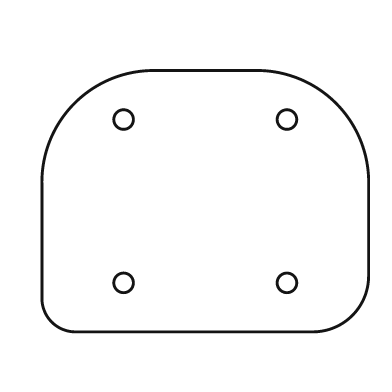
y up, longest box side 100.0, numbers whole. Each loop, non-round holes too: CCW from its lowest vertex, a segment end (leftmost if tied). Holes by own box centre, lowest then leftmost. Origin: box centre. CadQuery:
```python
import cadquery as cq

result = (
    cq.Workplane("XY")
    .moveTo(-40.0, -40.0)
    .lineTo(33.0, -40.0)
    .threePointArc((45.0, -35.0), (50.0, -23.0))
    .lineTo(50.0, 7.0)
    .threePointArc((40.0, 30.0), (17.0, 40.0))
    .lineTo(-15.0, 40.0)
    .threePointArc((-40.0, 30.0), (-50.0, 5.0))
    .lineTo(-50.0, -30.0)
    .threePointArc((-47.0, -37.0), (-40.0, -40.0))
    .close()
    .moveTo(-25.0, -25.0)
    .circle(3.0)
    .moveTo(25.0, -25.0)
    .circle(3.0)
    .moveTo(-25.0, 25.0)
    .circle(3.0)
    .moveTo(25.0, 25.0)
    .circle(3.0)
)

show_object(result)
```